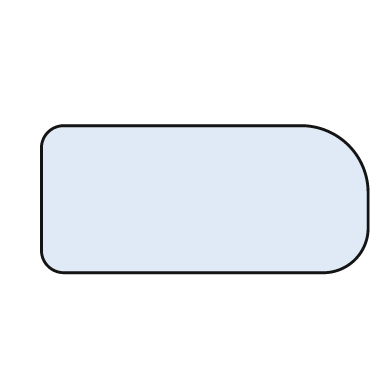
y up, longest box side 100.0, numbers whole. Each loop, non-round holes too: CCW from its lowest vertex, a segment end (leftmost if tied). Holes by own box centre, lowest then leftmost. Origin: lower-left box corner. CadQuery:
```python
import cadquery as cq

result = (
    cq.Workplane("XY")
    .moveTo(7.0, 0.0)
    .lineTo(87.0, 0.0)
    .threePointArc((96.0, 4.0), (100.0, 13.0))
    .lineTo(100.0, 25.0)
    .threePointArc((94.0, 39.0), (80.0, 45.0))
    .lineTo(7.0, 45.0)
    .threePointArc((2.0, 43.0), (0.0, 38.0))
    .lineTo(0.0, 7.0)
    .threePointArc((2.0, 2.0), (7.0, 0.0))
    .close()
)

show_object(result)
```